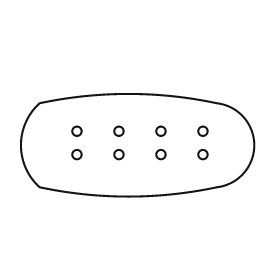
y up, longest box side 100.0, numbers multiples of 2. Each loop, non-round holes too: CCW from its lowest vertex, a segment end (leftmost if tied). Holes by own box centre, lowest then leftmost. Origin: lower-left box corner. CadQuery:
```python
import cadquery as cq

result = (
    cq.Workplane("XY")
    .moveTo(8.0, 4.0)
    .threePointArc((46.0, 0.0), (84.0, 4.0))
    .threePointArc((100.0, 22.0), (84.0, 40.0))
    .threePointArc((46.0, 44.0), (8.0, 40.0))
    .threePointArc((0.0, 22.0), (8.0, 4.0))
    .close()
    .moveTo(24.0, 18.0)
    .circle(2.0)
    .moveTo(42.0, 18.0)
    .circle(2.0)
    .moveTo(60.0, 18.0)
    .circle(2.0)
    .moveTo(78.0, 18.0)
    .circle(2.0)
    .moveTo(24.0, 28.0)
    .circle(2.0)
    .moveTo(42.0, 28.0)
    .circle(2.0)
    .moveTo(60.0, 28.0)
    .circle(2.0)
    .moveTo(78.0, 28.0)
    .circle(2.0)
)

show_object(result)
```